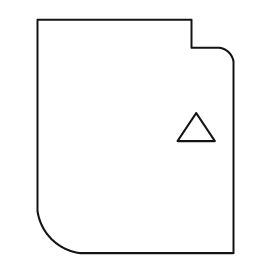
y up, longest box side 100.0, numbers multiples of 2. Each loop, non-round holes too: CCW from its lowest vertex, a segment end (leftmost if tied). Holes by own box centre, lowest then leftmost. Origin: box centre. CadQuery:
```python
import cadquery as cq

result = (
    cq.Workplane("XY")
    .moveTo(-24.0, -50.0)
    .lineTo(42.0, -50.0)
    .lineTo(42.0, 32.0)
    .threePointArc((40.0, 36.0), (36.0, 38.0))
    .lineTo(24.0, 38.0)
    .lineTo(24.0, 50.0)
    .lineTo(-42.0, 50.0)
    .lineTo(-42.0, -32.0)
    .threePointArc((-36.0, -44.0), (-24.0, -50.0))
    .close()
    .moveTo(18.0, -2.0)
    .lineTo(34.0, -2.0)
    .lineTo(26.0, 10.0)
    .close()
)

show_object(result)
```